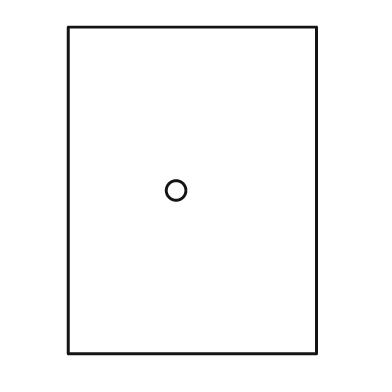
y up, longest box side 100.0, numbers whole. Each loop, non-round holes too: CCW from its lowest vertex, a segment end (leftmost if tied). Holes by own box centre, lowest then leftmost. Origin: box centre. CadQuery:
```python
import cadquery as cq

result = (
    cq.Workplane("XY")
    .moveTo(-38.0, -50.0)
    .lineTo(38.0, -50.0)
    .lineTo(38.0, 50.0)
    .lineTo(-38.0, 50.0)
    .close()
    .moveTo(-5.0, 0.0)
    .circle(3.0)
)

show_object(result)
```